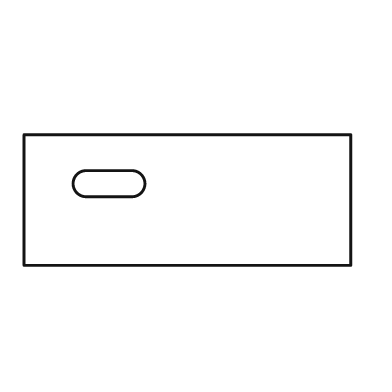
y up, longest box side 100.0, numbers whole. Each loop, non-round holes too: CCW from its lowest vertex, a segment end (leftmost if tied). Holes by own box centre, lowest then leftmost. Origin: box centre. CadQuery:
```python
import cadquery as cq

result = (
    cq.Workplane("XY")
    .moveTo(-50.0, -20.0)
    .lineTo(50.0, -20.0)
    .lineTo(50.0, 20.0)
    .lineTo(-50.0, 20.0)
    .close()
    .moveTo(-31.0, 1.0)
    .lineTo(-17.0, 1.0)
    .threePointArc((-13.0, 5.0), (-17.0, 9.0))
    .lineTo(-31.0, 9.0)
    .threePointArc((-35.0, 5.0), (-31.0, 1.0))
    .close()
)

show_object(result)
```